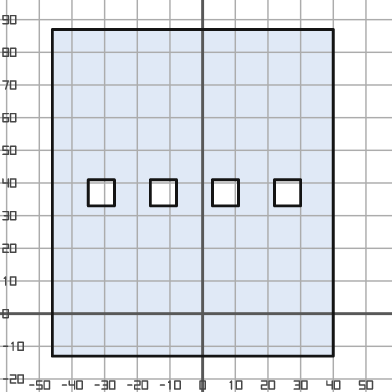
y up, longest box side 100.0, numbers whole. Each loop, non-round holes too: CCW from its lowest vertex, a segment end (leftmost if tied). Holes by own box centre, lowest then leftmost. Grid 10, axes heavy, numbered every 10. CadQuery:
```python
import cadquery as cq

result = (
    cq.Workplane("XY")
    .moveTo(-46.0, -13.0)
    .lineTo(40.0, -13.0)
    .lineTo(40.0, 87.0)
    .lineTo(-46.0, 87.0)
    .close()
    .moveTo(-35.0, 33.0)
    .lineTo(-27.0, 33.0)
    .lineTo(-27.0, 41.0)
    .lineTo(-35.0, 41.0)
    .close()
    .moveTo(-16.0, 33.0)
    .lineTo(-8.0, 33.0)
    .lineTo(-8.0, 41.0)
    .lineTo(-16.0, 41.0)
    .close()
    .moveTo(3.0, 33.0)
    .lineTo(11.0, 33.0)
    .lineTo(11.0, 41.0)
    .lineTo(3.0, 41.0)
    .close()
    .moveTo(22.0, 33.0)
    .lineTo(30.0, 33.0)
    .lineTo(30.0, 41.0)
    .lineTo(22.0, 41.0)
    .close()
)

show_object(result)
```